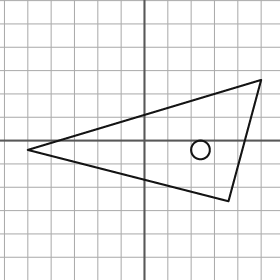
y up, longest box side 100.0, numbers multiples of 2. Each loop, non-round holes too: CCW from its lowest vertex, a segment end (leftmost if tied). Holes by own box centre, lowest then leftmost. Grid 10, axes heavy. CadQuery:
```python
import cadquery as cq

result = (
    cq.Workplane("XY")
    .moveTo(36.0, -26.0)
    .lineTo(50.0, 26.0)
    .lineTo(-50.0, -4.0)
    .close()
    .moveTo(24.0, -4.0)
    .circle(4.0)
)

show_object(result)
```